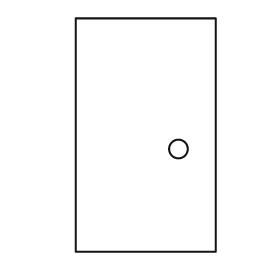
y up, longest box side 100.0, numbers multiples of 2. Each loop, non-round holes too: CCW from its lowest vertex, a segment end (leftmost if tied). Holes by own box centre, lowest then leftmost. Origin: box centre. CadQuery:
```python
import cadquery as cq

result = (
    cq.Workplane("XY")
    .moveTo(-30.0, -50.0)
    .lineTo(30.0, -50.0)
    .lineTo(30.0, 50.0)
    .lineTo(-30.0, 50.0)
    .close()
    .moveTo(14.0, -6.0)
    .circle(4.0)
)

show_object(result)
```